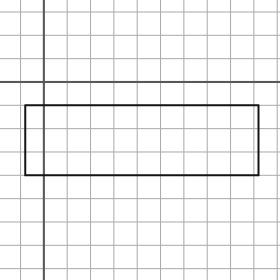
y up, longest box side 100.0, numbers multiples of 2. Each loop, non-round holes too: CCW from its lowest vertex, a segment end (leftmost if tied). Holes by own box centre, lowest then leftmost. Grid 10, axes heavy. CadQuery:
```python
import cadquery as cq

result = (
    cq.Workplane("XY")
    .moveTo(-8.0, -40.0)
    .lineTo(92.0, -40.0)
    .lineTo(92.0, -10.0)
    .lineTo(-8.0, -10.0)
    .close()
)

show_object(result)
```